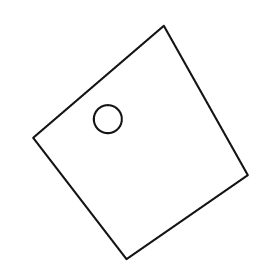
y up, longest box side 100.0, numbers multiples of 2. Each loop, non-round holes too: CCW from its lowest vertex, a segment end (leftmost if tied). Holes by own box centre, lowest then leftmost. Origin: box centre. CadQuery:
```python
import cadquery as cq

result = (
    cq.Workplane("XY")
    .moveTo(-6.0, -50.0)
    .lineTo(46.0, -14.0)
    .lineTo(10.0, 50.0)
    .lineTo(-46.0, 2.0)
    .close()
    .moveTo(-14.0, 10.0)
    .circle(6.0)
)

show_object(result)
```